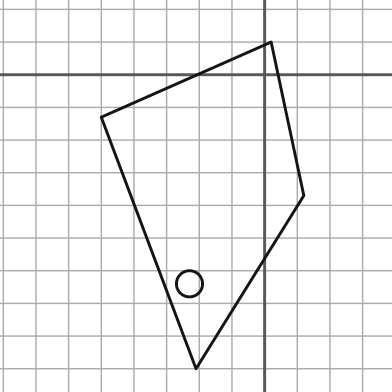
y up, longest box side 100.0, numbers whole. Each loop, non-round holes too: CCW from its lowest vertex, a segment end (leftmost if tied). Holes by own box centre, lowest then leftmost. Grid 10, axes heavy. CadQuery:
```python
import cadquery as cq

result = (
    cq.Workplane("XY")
    .moveTo(-21.0, -90.0)
    .lineTo(12.0, -37.0)
    .lineTo(2.0, 10.0)
    .lineTo(-50.0, -13.0)
    .close()
    .moveTo(-23.0, -64.0)
    .circle(4.0)
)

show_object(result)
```